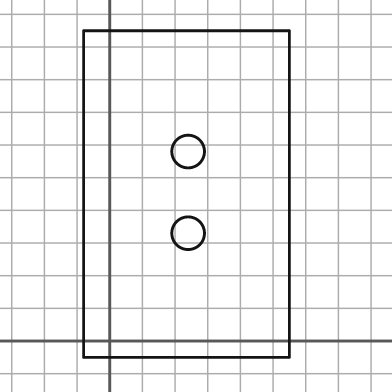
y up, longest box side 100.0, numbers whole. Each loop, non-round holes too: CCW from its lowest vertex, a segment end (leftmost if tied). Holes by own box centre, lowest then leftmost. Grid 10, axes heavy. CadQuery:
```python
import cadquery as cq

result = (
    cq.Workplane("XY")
    .moveTo(-8.0, -5.0)
    .lineTo(55.0, -5.0)
    .lineTo(55.0, 95.0)
    .lineTo(-8.0, 95.0)
    .close()
    .moveTo(24.0, 33.0)
    .circle(5.0)
    .moveTo(24.0, 58.0)
    .circle(5.0)
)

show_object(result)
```